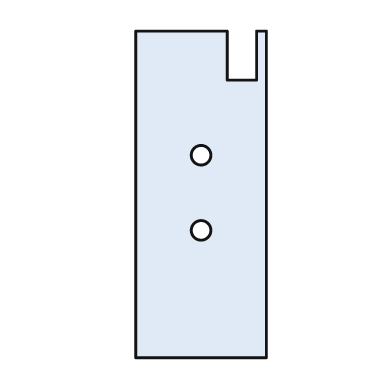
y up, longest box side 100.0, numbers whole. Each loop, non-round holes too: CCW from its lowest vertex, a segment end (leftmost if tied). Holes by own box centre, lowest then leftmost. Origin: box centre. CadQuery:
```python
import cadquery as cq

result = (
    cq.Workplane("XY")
    .moveTo(-20.0, -50.0)
    .lineTo(20.0, -50.0)
    .lineTo(20.0, 50.0)
    .lineTo(17.0, 50.0)
    .lineTo(17.0, 35.0)
    .lineTo(8.0, 35.0)
    .lineTo(8.0, 50.0)
    .lineTo(-20.0, 50.0)
    .close()
    .moveTo(0.0, -11.0)
    .circle(3.0)
    .moveTo(0.0, 12.0)
    .circle(3.0)
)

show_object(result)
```